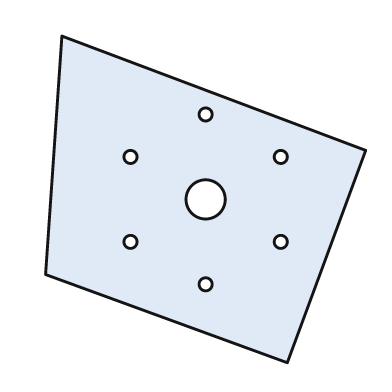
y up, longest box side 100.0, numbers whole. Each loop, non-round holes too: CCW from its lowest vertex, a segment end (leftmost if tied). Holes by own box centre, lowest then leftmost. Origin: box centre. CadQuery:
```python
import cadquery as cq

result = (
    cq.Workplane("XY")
    .moveTo(25.0, -50.0)
    .lineTo(49.0, 15.0)
    .lineTo(-44.0, 50.0)
    .lineTo(-49.0, -23.0)
    .close()
    .moveTo(0.0, -26.0)
    .circle(2.0)
    .moveTo(-23.0, -13.0)
    .circle(2.0)
    .moveTo(23.0, -13.0)
    .circle(2.0)
    .moveTo(0.0, 0.0)
    .circle(6.0)
    .moveTo(-23.0, 13.0)
    .circle(2.0)
    .moveTo(23.0, 13.0)
    .circle(2.0)
    .moveTo(0.0, 26.0)
    .circle(2.0)
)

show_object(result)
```